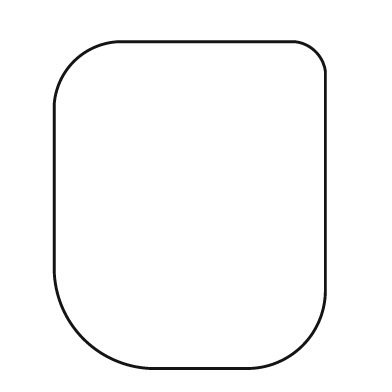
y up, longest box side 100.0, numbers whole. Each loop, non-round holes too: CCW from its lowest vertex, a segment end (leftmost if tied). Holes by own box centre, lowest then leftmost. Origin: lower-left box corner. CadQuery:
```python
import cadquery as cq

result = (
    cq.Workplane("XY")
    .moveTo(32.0, 0.0)
    .lineTo(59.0, 0.0)
    .threePointArc((76.0, 7.0), (83.0, 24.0))
    .lineTo(83.0, 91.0)
    .threePointArc((80.0, 97.0), (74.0, 100.0))
    .lineTo(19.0, 100.0)
    .threePointArc((6.0, 94.0), (0.0, 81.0))
    .lineTo(0.0, 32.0)
    .threePointArc((9.0, 9.0), (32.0, 0.0))
    .close()
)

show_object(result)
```